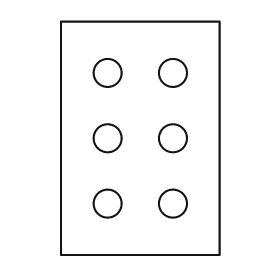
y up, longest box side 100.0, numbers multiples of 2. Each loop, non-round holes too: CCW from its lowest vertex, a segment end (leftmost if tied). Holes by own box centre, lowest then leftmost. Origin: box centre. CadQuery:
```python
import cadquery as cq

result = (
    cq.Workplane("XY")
    .moveTo(-34.0, -50.0)
    .lineTo(34.0, -50.0)
    .lineTo(34.0, 50.0)
    .lineTo(-34.0, 50.0)
    .close()
    .moveTo(-14.0, -28.0)
    .circle(6.0)
    .moveTo(14.0, -28.0)
    .circle(6.0)
    .moveTo(-14.0, 0.0)
    .circle(6.0)
    .moveTo(14.0, 0.0)
    .circle(6.0)
    .moveTo(-14.0, 28.0)
    .circle(6.0)
    .moveTo(14.0, 28.0)
    .circle(6.0)
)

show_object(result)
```